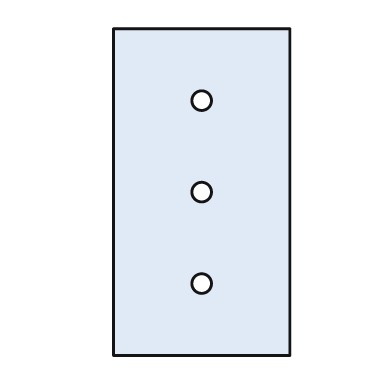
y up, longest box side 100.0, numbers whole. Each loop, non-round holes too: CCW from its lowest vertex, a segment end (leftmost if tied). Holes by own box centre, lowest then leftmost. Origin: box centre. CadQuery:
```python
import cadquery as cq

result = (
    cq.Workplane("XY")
    .moveTo(-27.0, -50.0)
    .lineTo(27.0, -50.0)
    .lineTo(27.0, 50.0)
    .lineTo(-27.0, 50.0)
    .close()
    .moveTo(0.0, -28.0)
    .circle(3.0)
    .moveTo(0.0, 0.0)
    .circle(3.0)
    .moveTo(0.0, 28.0)
    .circle(3.0)
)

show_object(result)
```